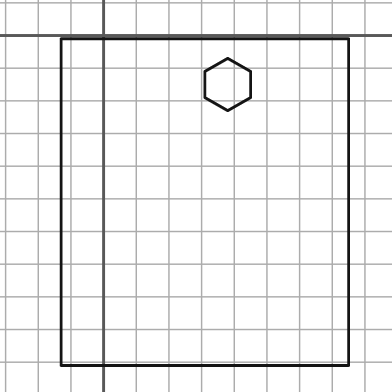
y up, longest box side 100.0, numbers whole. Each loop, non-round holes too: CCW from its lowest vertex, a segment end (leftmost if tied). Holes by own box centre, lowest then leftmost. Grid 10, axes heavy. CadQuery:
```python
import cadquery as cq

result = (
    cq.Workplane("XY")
    .moveTo(-13.0, -101.0)
    .lineTo(75.0, -101.0)
    .lineTo(75.0, -1.0)
    .lineTo(-13.0, -1.0)
    .close()
    .moveTo(38.0, -23.0)
    .lineTo(45.0, -19.0)
    .lineTo(45.0, -11.0)
    .lineTo(38.0, -7.0)
    .lineTo(31.0, -11.0)
    .lineTo(31.0, -19.0)
    .close()
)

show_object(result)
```